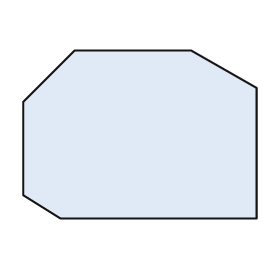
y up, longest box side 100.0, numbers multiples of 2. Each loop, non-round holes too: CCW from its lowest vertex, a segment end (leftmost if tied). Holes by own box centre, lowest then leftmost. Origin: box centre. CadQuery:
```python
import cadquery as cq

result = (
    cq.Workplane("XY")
    .moveTo(-34.0, -36.0)
    .lineTo(50.0, -36.0)
    .lineTo(50.0, 20.0)
    .lineTo(22.0, 36.0)
    .lineTo(-28.0, 36.0)
    .lineTo(-50.0, 14.0)
    .lineTo(-50.0, -26.0)
    .close()
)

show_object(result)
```